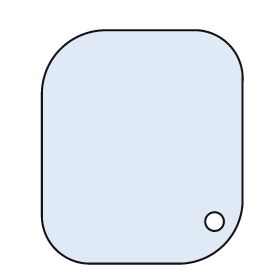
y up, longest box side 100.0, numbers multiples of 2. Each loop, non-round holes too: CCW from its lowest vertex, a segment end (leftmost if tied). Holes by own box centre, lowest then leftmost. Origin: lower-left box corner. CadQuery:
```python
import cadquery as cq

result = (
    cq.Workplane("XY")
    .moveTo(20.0, 0.0)
    .lineTo(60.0, 0.0)
    .threePointArc((78.0, 8.0), (86.0, 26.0))
    .lineTo(86.0, 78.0)
    .threePointArc((80.0, 94.0), (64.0, 100.0))
    .lineTo(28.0, 100.0)
    .threePointArc((8.0, 92.0), (0.0, 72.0))
    .lineTo(0.0, 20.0)
    .threePointArc((6.0, 6.0), (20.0, 0.0))
    .close()
    .moveTo(74.0, 18.0)
    .circle(4.0)
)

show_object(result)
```